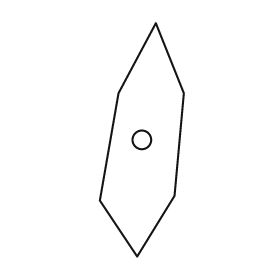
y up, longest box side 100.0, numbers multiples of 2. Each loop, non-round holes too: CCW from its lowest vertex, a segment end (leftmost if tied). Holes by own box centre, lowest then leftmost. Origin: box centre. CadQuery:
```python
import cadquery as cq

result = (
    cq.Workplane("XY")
    .moveTo(-2.0, -50.0)
    .lineTo(14.0, -24.0)
    .lineTo(18.0, 20.0)
    .lineTo(6.0, 50.0)
    .lineTo(-10.0, 20.0)
    .lineTo(-18.0, -26.0)
    .close()
    .moveTo(0.0, 0.0)
    .circle(4.0)
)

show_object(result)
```